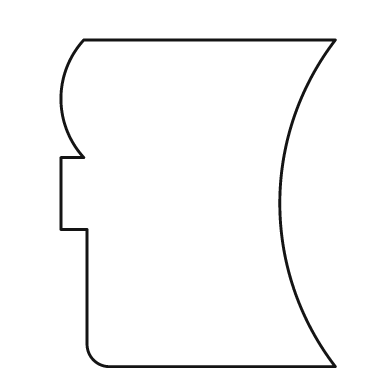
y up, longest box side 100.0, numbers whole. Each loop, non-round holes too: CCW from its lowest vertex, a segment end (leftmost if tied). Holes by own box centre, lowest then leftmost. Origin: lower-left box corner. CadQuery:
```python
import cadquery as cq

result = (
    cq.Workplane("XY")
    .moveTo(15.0, 0.0)
    .lineTo(84.0, 0.0)
    .threePointArc((67.0, 50.0), (84.0, 100.0))
    .lineTo(7.0, 100.0)
    .threePointArc((0.0, 82.0), (7.0, 64.0))
    .lineTo(0.0, 64.0)
    .lineTo(0.0, 42.0)
    .lineTo(8.0, 42.0)
    .lineTo(8.0, 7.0)
    .threePointArc((10.0, 2.0), (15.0, 0.0))
    .close()
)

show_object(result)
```